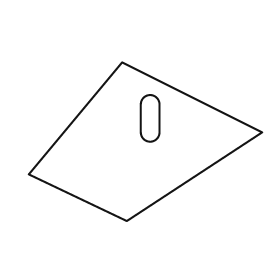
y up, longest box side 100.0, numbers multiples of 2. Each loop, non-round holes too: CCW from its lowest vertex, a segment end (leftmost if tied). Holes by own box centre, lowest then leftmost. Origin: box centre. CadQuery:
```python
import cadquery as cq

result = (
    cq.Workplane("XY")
    .moveTo(-8.0, -34.0)
    .lineTo(50.0, 4.0)
    .lineTo(-10.0, 34.0)
    .lineTo(-50.0, -14.0)
    .close()
    .moveTo(-2.0, 4.0)
    .threePointArc((2.0, 0.0), (6.0, 4.0))
    .lineTo(6.0, 16.0)
    .threePointArc((2.0, 20.0), (-2.0, 16.0))
    .close()
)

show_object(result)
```